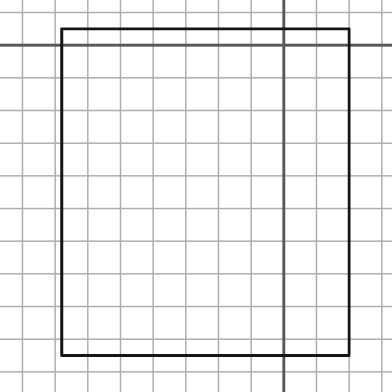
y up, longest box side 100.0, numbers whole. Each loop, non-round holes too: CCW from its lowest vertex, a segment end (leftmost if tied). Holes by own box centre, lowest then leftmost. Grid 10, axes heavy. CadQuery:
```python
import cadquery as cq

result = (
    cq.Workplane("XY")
    .moveTo(-68.0, -95.0)
    .lineTo(20.0, -95.0)
    .lineTo(20.0, 5.0)
    .lineTo(-68.0, 5.0)
    .close()
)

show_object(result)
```